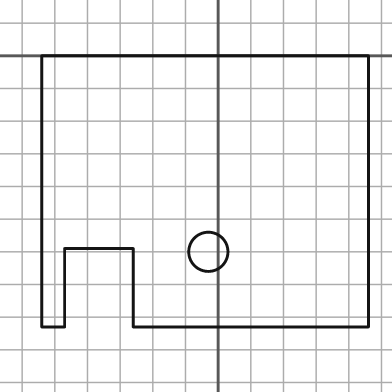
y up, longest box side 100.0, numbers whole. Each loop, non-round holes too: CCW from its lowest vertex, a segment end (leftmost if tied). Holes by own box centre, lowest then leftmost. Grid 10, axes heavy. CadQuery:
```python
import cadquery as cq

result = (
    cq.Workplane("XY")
    .moveTo(-54.0, -83.0)
    .lineTo(-47.0, -83.0)
    .lineTo(-47.0, -59.0)
    .lineTo(-26.0, -59.0)
    .lineTo(-26.0, -83.0)
    .lineTo(46.0, -83.0)
    .lineTo(46.0, 0.0)
    .lineTo(-54.0, 0.0)
    .close()
    .moveTo(-3.0, -60.0)
    .circle(6.0)
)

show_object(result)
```